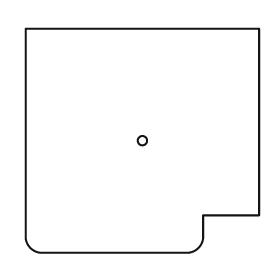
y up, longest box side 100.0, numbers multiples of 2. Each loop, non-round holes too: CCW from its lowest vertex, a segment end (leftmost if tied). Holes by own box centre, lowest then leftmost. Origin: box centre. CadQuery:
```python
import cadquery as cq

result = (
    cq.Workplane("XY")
    .moveTo(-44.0, -48.0)
    .lineTo(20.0, -48.0)
    .threePointArc((24.0, -46.0), (26.0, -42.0))
    .lineTo(26.0, -32.0)
    .lineTo(50.0, -32.0)
    .lineTo(50.0, 48.0)
    .lineTo(-50.0, 48.0)
    .lineTo(-50.0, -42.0)
    .threePointArc((-48.0, -46.0), (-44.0, -48.0))
    .close()
    .moveTo(0.0, 0.0)
    .circle(2.0)
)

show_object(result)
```